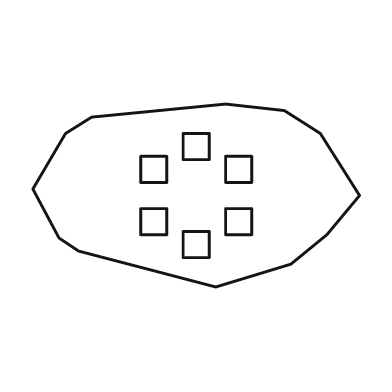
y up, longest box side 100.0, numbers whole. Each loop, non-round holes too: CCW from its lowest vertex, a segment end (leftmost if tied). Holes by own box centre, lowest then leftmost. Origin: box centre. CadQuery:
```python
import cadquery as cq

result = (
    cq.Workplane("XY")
    .moveTo(6.0, -28.0)
    .lineTo(29.0, -21.0)
    .lineTo(40.0, -12.0)
    .lineTo(50.0, 0.0)
    .lineTo(38.0, 19.0)
    .lineTo(27.0, 26.0)
    .lineTo(9.0, 28.0)
    .lineTo(-32.0, 24.0)
    .lineTo(-40.0, 19.0)
    .lineTo(-50.0, 2.0)
    .lineTo(-42.0, -13.0)
    .lineTo(-36.0, -17.0)
    .close()
    .moveTo(-4.0, -19.0)
    .lineTo(4.0, -19.0)
    .lineTo(4.0, -11.0)
    .lineTo(-4.0, -11.0)
    .close()
    .moveTo(-17.0, -12.0)
    .lineTo(-9.0, -12.0)
    .lineTo(-9.0, -4.0)
    .lineTo(-17.0, -4.0)
    .close()
    .moveTo(9.0, -12.0)
    .lineTo(17.0, -12.0)
    .lineTo(17.0, -4.0)
    .lineTo(9.0, -4.0)
    .close()
    .moveTo(-17.0, 4.0)
    .lineTo(-9.0, 4.0)
    .lineTo(-9.0, 12.0)
    .lineTo(-17.0, 12.0)
    .close()
    .moveTo(9.0, 4.0)
    .lineTo(17.0, 4.0)
    .lineTo(17.0, 12.0)
    .lineTo(9.0, 12.0)
    .close()
    .moveTo(-4.0, 11.0)
    .lineTo(4.0, 11.0)
    .lineTo(4.0, 19.0)
    .lineTo(-4.0, 19.0)
    .close()
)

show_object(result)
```